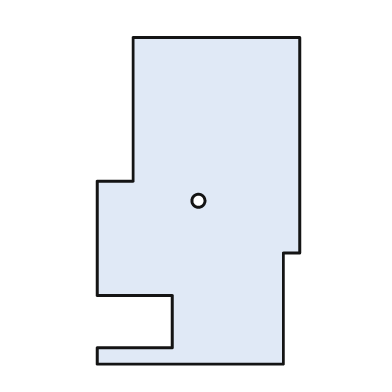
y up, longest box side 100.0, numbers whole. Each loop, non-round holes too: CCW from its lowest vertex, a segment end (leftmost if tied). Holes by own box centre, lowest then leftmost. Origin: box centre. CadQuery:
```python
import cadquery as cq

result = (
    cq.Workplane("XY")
    .moveTo(-31.0, -50.0)
    .lineTo(26.0, -50.0)
    .lineTo(26.0, -16.0)
    .lineTo(31.0, -16.0)
    .lineTo(31.0, 50.0)
    .lineTo(-20.0, 50.0)
    .lineTo(-20.0, 6.0)
    .lineTo(-31.0, 6.0)
    .lineTo(-31.0, -29.0)
    .lineTo(-8.0, -29.0)
    .lineTo(-8.0, -45.0)
    .lineTo(-31.0, -45.0)
    .close()
    .moveTo(0.0, 0.0)
    .circle(2.0)
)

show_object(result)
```